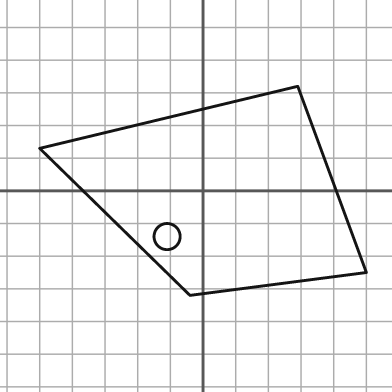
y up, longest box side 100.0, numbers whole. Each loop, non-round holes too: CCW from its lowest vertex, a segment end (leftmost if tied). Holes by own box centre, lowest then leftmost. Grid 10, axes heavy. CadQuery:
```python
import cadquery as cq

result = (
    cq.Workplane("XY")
    .moveTo(-4.0, -32.0)
    .lineTo(50.0, -25.0)
    .lineTo(29.0, 32.0)
    .lineTo(-50.0, 13.0)
    .close()
    .moveTo(-11.0, -14.0)
    .circle(4.0)
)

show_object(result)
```